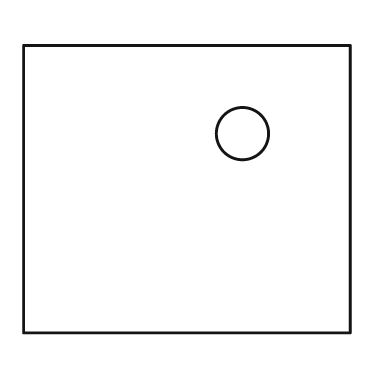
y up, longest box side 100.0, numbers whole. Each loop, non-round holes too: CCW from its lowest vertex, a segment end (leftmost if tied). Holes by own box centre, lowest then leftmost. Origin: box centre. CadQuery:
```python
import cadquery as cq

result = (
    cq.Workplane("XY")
    .moveTo(-50.0, -44.0)
    .lineTo(50.0, -44.0)
    .lineTo(50.0, 44.0)
    .lineTo(-50.0, 44.0)
    .close()
    .moveTo(17.0, 17.0)
    .circle(8.0)
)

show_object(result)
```